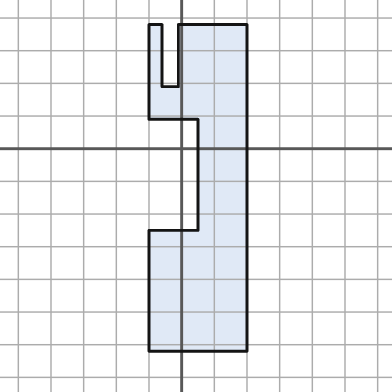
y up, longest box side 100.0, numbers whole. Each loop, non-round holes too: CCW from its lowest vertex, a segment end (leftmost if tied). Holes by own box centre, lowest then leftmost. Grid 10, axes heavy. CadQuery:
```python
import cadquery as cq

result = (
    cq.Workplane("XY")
    .moveTo(-10.0, -62.0)
    .lineTo(20.0, -62.0)
    .lineTo(20.0, 38.0)
    .lineTo(-1.0, 38.0)
    .lineTo(-1.0, 19.0)
    .lineTo(-6.0, 19.0)
    .lineTo(-6.0, 38.0)
    .lineTo(-10.0, 38.0)
    .lineTo(-10.0, 9.0)
    .lineTo(5.0, 9.0)
    .lineTo(5.0, -25.0)
    .lineTo(-10.0, -25.0)
    .close()
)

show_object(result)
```